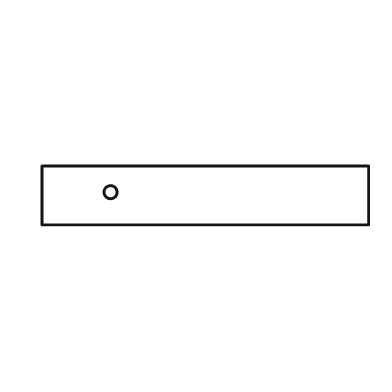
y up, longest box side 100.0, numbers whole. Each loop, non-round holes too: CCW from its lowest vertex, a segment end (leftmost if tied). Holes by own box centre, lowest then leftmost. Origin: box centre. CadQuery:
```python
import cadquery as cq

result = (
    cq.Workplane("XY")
    .moveTo(-50.0, -9.0)
    .lineTo(50.0, -9.0)
    .lineTo(50.0, 9.0)
    .lineTo(-50.0, 9.0)
    .close()
    .moveTo(-29.0, 1.0)
    .circle(2.0)
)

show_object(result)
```